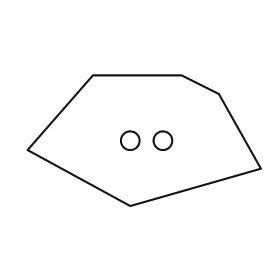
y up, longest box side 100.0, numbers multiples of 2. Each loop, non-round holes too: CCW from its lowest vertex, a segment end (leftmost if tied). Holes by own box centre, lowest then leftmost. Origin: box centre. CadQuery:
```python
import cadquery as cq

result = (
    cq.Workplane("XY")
    .moveTo(-6.0, -28.0)
    .lineTo(50.0, -12.0)
    .lineTo(32.0, 20.0)
    .lineTo(16.0, 28.0)
    .lineTo(-22.0, 28.0)
    .lineTo(-50.0, -4.0)
    .close()
    .moveTo(-6.0, 0.0)
    .circle(4.0)
    .moveTo(8.0, 0.0)
    .circle(4.0)
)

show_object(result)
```